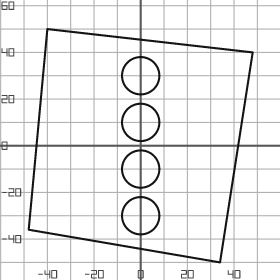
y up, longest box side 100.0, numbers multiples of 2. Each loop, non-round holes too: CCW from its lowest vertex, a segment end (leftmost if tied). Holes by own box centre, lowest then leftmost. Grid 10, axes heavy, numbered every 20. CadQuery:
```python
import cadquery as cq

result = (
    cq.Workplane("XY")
    .moveTo(34.0, -50.0)
    .lineTo(48.0, 40.0)
    .lineTo(-40.0, 50.0)
    .lineTo(-48.0, -36.0)
    .close()
    .moveTo(0.0, -30.0)
    .circle(8.0)
    .moveTo(0.0, -10.0)
    .circle(8.0)
    .moveTo(0.0, 10.0)
    .circle(8.0)
    .moveTo(0.0, 30.0)
    .circle(8.0)
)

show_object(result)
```